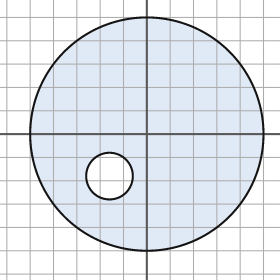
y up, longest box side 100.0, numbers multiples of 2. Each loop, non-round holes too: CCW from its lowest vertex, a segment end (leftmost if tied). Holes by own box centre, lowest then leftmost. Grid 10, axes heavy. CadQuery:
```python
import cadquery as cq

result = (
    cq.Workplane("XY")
    .moveTo(0.0, 0.0)
    .circle(50.0)
    .moveTo(-16.0, -18.0)
    .circle(10.0)
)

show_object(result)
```